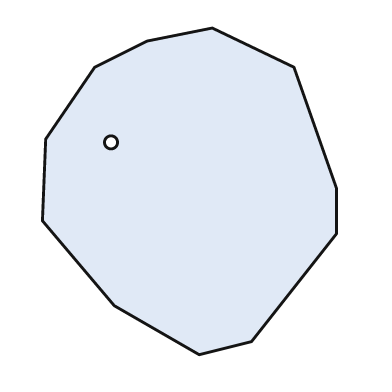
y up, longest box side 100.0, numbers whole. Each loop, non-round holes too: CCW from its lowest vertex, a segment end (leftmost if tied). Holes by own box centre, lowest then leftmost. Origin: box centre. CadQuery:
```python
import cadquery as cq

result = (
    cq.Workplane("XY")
    .moveTo(3.0, -50.0)
    .lineTo(19.0, -46.0)
    .lineTo(45.0, -13.0)
    .lineTo(45.0, 1.0)
    .lineTo(32.0, 38.0)
    .lineTo(7.0, 50.0)
    .lineTo(-13.0, 46.0)
    .lineTo(-29.0, 38.0)
    .lineTo(-44.0, 16.0)
    .lineTo(-45.0, -9.0)
    .lineTo(-23.0, -35.0)
    .close()
    .moveTo(-24.0, 15.0)
    .circle(2.0)
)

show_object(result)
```